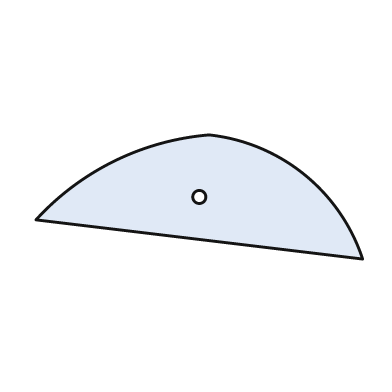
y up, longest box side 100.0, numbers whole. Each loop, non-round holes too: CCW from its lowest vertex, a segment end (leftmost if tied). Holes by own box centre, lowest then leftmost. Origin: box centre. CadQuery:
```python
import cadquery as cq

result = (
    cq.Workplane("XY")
    .moveTo(50.0, -19.0)
    .threePointArc((32.0, 7.0), (3.0, 19.0))
    .threePointArc((-26.0, 11.0), (-50.0, -7.0))
    .close()
    .moveTo(0.0, 0.0)
    .circle(2.0)
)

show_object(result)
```